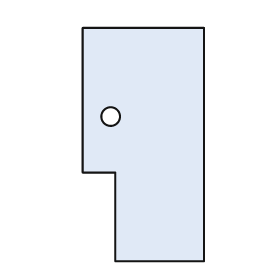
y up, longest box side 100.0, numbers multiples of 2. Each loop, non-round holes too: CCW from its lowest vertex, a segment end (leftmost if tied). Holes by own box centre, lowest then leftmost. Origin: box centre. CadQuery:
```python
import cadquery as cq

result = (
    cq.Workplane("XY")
    .moveTo(-12.0, -50.0)
    .lineTo(26.0, -50.0)
    .lineTo(26.0, 50.0)
    .lineTo(-26.0, 50.0)
    .lineTo(-26.0, -12.0)
    .lineTo(-12.0, -12.0)
    .close()
    .moveTo(-14.0, 12.0)
    .circle(4.0)
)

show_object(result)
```